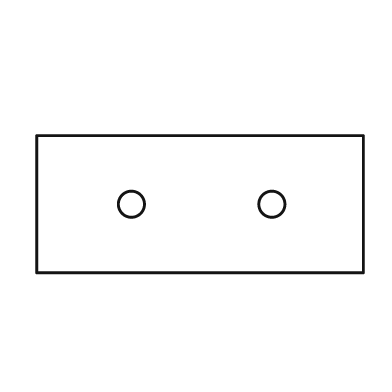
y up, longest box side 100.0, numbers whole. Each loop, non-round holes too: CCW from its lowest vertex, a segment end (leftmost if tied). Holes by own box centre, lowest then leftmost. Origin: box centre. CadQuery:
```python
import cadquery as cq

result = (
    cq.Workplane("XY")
    .moveTo(-50.0, -21.0)
    .lineTo(50.0, -21.0)
    .lineTo(50.0, 21.0)
    .lineTo(-50.0, 21.0)
    .close()
    .moveTo(-21.0, 0.0)
    .circle(4.0)
    .moveTo(22.0, 0.0)
    .circle(4.0)
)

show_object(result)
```